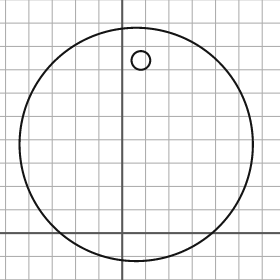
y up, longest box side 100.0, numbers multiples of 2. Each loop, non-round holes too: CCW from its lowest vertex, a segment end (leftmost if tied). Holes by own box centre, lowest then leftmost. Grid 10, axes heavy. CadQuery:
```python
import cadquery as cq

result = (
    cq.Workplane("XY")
    .moveTo(6.0, 38.0)
    .circle(50.0)
    .moveTo(8.0, 74.0)
    .circle(4.0)
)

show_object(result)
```